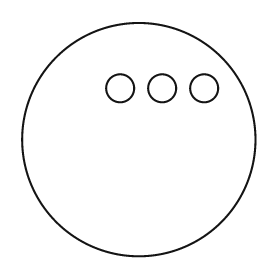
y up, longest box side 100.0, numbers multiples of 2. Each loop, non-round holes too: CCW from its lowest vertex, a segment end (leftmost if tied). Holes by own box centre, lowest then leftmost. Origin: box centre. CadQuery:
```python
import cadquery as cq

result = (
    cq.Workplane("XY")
    .moveTo(0.0, 0.0)
    .circle(50.0)
    .moveTo(-8.0, 22.0)
    .circle(6.0)
    .moveTo(10.0, 22.0)
    .circle(6.0)
    .moveTo(28.0, 22.0)
    .circle(6.0)
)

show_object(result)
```